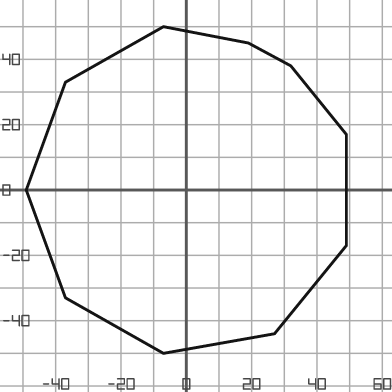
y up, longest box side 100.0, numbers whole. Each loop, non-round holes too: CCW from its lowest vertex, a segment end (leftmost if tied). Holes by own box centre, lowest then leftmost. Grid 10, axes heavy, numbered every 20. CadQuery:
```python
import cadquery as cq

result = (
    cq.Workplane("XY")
    .moveTo(-7.0, -50.0)
    .lineTo(27.0, -44.0)
    .lineTo(49.0, -17.0)
    .lineTo(49.0, 17.0)
    .lineTo(32.0, 38.0)
    .lineTo(19.0, 45.0)
    .lineTo(-7.0, 50.0)
    .lineTo(-37.0, 33.0)
    .lineTo(-49.0, 0.0)
    .lineTo(-37.0, -33.0)
    .close()
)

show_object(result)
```